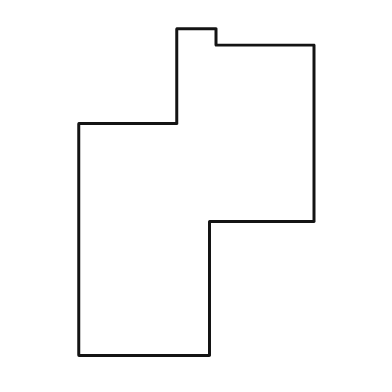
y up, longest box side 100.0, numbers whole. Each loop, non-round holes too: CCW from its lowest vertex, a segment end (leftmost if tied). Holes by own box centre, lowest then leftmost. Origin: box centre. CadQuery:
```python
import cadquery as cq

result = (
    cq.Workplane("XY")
    .moveTo(-36.0, -50.0)
    .lineTo(4.0, -50.0)
    .lineTo(4.0, -9.0)
    .lineTo(36.0, -9.0)
    .lineTo(36.0, 45.0)
    .lineTo(6.0, 45.0)
    .lineTo(6.0, 50.0)
    .lineTo(-6.0, 50.0)
    .lineTo(-6.0, 21.0)
    .lineTo(-36.0, 21.0)
    .close()
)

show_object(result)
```